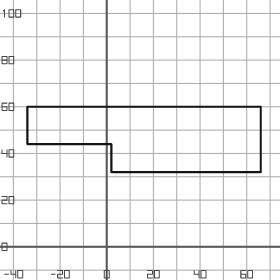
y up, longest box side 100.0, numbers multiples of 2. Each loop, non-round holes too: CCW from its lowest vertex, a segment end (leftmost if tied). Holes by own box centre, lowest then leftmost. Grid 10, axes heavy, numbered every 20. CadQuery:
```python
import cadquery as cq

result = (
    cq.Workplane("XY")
    .moveTo(2.0, 32.0)
    .lineTo(66.0, 32.0)
    .lineTo(66.0, 60.0)
    .lineTo(-34.0, 60.0)
    .lineTo(-34.0, 44.0)
    .lineTo(2.0, 44.0)
    .close()
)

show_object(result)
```